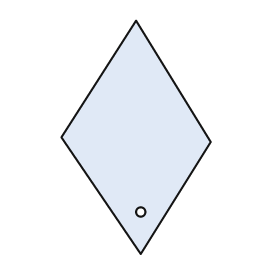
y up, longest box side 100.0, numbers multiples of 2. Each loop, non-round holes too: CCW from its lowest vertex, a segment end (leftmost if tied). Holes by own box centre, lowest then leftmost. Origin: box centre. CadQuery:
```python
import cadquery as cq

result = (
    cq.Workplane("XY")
    .moveTo(2.0, -50.0)
    .lineTo(32.0, -2.0)
    .lineTo(0.0, 50.0)
    .lineTo(-32.0, 0.0)
    .close()
    .moveTo(2.0, -32.0)
    .circle(2.0)
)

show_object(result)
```